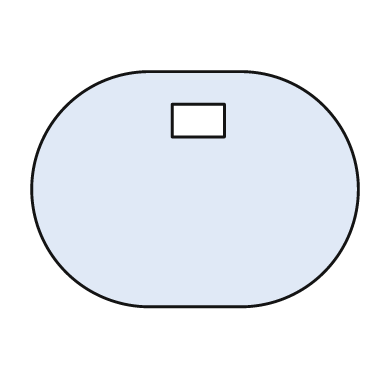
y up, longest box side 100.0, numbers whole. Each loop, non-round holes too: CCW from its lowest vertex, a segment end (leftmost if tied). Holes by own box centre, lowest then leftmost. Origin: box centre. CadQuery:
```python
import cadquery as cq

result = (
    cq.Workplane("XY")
    .moveTo(-14.0, -36.0)
    .lineTo(14.0, -36.0)
    .threePointArc((50.0, 0.0), (14.0, 36.0))
    .lineTo(-14.0, 36.0)
    .threePointArc((-50.0, 0.0), (-14.0, -36.0))
    .close()
    .moveTo(-7.0, 16.0)
    .lineTo(9.0, 16.0)
    .lineTo(9.0, 26.0)
    .lineTo(-7.0, 26.0)
    .close()
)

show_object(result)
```